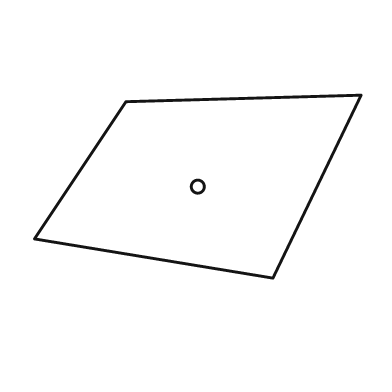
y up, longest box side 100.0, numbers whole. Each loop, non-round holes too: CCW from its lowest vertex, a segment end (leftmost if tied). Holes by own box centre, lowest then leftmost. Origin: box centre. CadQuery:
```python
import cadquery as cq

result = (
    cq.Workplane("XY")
    .moveTo(23.0, -28.0)
    .lineTo(50.0, 28.0)
    .lineTo(-22.0, 26.0)
    .lineTo(-50.0, -16.0)
    .close()
    .moveTo(0.0, 0.0)
    .circle(2.0)
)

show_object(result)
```